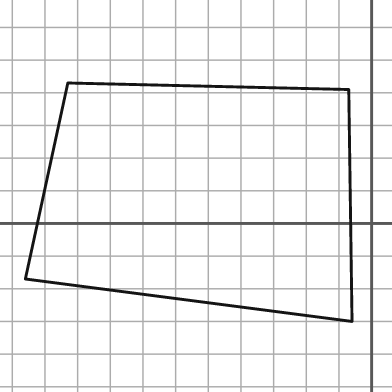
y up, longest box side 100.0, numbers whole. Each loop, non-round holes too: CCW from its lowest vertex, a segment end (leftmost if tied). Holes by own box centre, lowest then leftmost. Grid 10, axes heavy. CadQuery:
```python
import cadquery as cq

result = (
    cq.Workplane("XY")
    .moveTo(-6.0, -30.0)
    .lineTo(-7.0, 41.0)
    .lineTo(-93.0, 43.0)
    .lineTo(-106.0, -17.0)
    .close()
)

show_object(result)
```